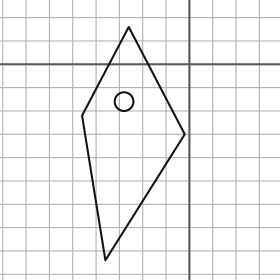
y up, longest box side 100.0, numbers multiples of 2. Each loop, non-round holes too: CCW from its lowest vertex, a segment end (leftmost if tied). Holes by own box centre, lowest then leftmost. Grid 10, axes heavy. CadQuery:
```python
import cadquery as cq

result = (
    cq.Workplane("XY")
    .moveTo(-36.0, -84.0)
    .lineTo(-2.0, -30.0)
    .lineTo(-26.0, 16.0)
    .lineTo(-46.0, -22.0)
    .close()
    .moveTo(-28.0, -16.0)
    .circle(4.0)
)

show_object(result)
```